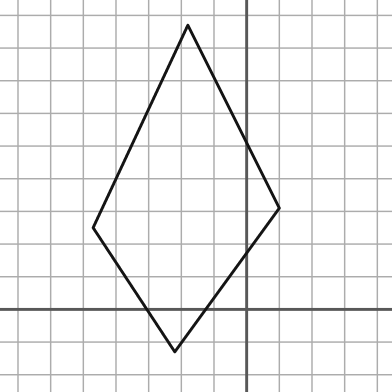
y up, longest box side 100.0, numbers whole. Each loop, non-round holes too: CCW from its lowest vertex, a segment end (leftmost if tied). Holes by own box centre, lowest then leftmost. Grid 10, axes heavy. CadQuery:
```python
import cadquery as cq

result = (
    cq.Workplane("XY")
    .moveTo(-22.0, -13.0)
    .lineTo(10.0, 31.0)
    .lineTo(-18.0, 87.0)
    .lineTo(-47.0, 25.0)
    .close()
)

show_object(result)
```